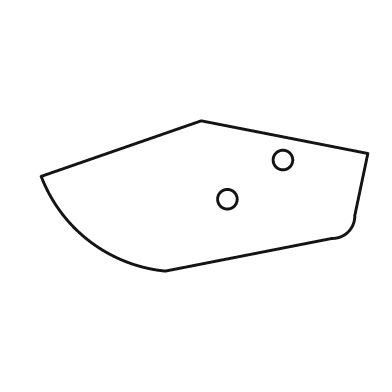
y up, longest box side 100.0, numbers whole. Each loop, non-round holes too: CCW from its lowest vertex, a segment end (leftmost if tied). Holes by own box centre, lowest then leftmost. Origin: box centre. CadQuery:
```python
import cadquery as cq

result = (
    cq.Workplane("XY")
    .moveTo(-12.0, -23.0)
    .lineTo(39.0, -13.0)
    .threePointArc((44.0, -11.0), (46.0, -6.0))
    .lineTo(50.0, 13.0)
    .lineTo(-1.0, 23.0)
    .lineTo(-50.0, 6.0)
    .threePointArc((-35.0, -14.0), (-12.0, -23.0))
    .close()
    .moveTo(7.0, -1.0)
    .circle(3.0)
    .moveTo(24.0, 11.0)
    .circle(3.0)
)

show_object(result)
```